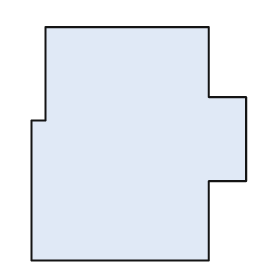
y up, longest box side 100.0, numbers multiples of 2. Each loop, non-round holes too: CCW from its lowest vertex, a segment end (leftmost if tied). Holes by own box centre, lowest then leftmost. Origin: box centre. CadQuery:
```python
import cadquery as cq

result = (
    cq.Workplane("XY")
    .moveTo(-46.0, -50.0)
    .lineTo(30.0, -50.0)
    .lineTo(30.0, -16.0)
    .lineTo(46.0, -16.0)
    .lineTo(46.0, 20.0)
    .lineTo(30.0, 20.0)
    .lineTo(30.0, 50.0)
    .lineTo(-40.0, 50.0)
    .lineTo(-40.0, 10.0)
    .lineTo(-46.0, 10.0)
    .close()
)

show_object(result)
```